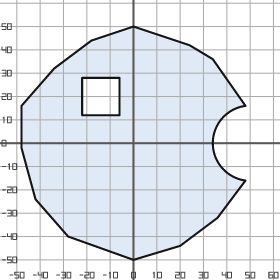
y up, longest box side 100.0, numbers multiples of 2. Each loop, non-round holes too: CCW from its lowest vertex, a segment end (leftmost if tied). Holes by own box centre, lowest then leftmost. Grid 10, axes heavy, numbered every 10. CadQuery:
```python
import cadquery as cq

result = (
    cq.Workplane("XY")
    .moveTo(0.0, -50.0)
    .lineTo(20.0, -44.0)
    .lineTo(36.0, -32.0)
    .lineTo(48.0, -16.0)
    .threePointArc((34.0, 0.0), (48.0, 16.0))
    .lineTo(34.0, 36.0)
    .lineTo(24.0, 42.0)
    .lineTo(0.0, 50.0)
    .lineTo(-18.0, 44.0)
    .lineTo(-34.0, 32.0)
    .lineTo(-48.0, 16.0)
    .lineTo(-48.0, -2.0)
    .lineTo(-42.0, -24.0)
    .lineTo(-28.0, -40.0)
    .close()
    .moveTo(-22.0, 12.0)
    .lineTo(-6.0, 12.0)
    .lineTo(-6.0, 28.0)
    .lineTo(-22.0, 28.0)
    .close()
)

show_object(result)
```